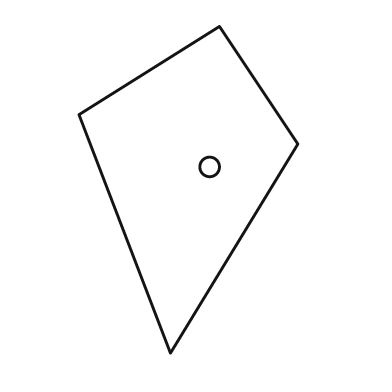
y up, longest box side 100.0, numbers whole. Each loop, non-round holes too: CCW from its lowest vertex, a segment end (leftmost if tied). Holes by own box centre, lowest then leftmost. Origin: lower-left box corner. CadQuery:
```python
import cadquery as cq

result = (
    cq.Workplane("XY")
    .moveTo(28.0, 0.0)
    .lineTo(67.0, 64.0)
    .lineTo(43.0, 100.0)
    .lineTo(0.0, 73.0)
    .close()
    .moveTo(40.0, 57.0)
    .circle(3.0)
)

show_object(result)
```